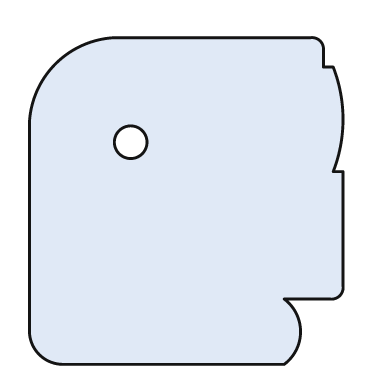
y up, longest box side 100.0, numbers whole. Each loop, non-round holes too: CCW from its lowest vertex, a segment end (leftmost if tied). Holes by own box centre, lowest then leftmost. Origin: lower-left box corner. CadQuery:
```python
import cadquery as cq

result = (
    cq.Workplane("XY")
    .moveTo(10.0, 0.0)
    .lineTo(78.0, 0.0)
    .threePointArc((83.0, 10.0), (78.0, 20.0))
    .lineTo(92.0, 20.0)
    .threePointArc((95.0, 21.0), (96.0, 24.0))
    .lineTo(96.0, 59.0)
    .lineTo(93.0, 59.0)
    .threePointArc((96.0, 75.0), (93.0, 91.0))
    .lineTo(90.0, 91.0)
    .lineTo(90.0, 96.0)
    .threePointArc((89.0, 99.0), (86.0, 100.0))
    .lineTo(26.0, 100.0)
    .threePointArc((8.0, 92.0), (0.0, 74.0))
    .lineTo(0.0, 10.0)
    .threePointArc((3.0, 3.0), (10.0, 0.0))
    .close()
    .moveTo(31.0, 68.0)
    .circle(5.0)
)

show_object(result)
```